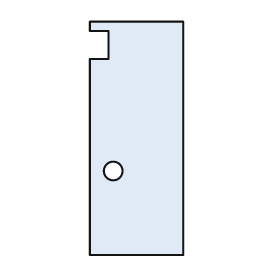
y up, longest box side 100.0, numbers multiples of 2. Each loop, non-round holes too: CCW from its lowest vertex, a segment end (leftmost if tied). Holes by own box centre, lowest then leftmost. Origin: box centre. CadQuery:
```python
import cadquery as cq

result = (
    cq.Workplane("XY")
    .moveTo(-20.0, -50.0)
    .lineTo(20.0, -50.0)
    .lineTo(20.0, 50.0)
    .lineTo(-20.0, 50.0)
    .lineTo(-20.0, 46.0)
    .lineTo(-12.0, 46.0)
    .lineTo(-12.0, 34.0)
    .lineTo(-20.0, 34.0)
    .close()
    .moveTo(-10.0, -14.0)
    .circle(4.0)
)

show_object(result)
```